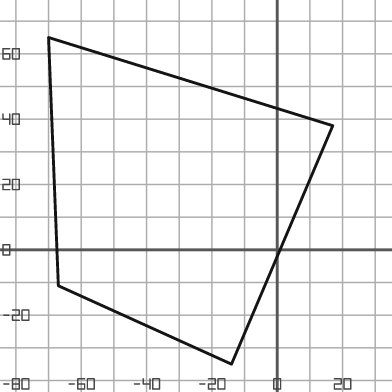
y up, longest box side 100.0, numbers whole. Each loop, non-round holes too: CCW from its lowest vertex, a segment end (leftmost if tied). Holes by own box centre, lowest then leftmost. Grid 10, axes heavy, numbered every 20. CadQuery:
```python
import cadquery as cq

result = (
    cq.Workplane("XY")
    .moveTo(-14.0, -35.0)
    .lineTo(17.0, 38.0)
    .lineTo(-70.0, 65.0)
    .lineTo(-67.0, -11.0)
    .close()
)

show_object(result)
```